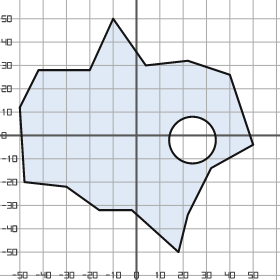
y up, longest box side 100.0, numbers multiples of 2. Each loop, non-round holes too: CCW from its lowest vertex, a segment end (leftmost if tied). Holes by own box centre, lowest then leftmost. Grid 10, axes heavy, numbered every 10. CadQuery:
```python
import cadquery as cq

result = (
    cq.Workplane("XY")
    .moveTo(18.0, -50.0)
    .lineTo(22.0, -34.0)
    .lineTo(32.0, -14.0)
    .lineTo(50.0, -4.0)
    .lineTo(40.0, 26.0)
    .lineTo(22.0, 32.0)
    .lineTo(4.0, 30.0)
    .lineTo(-10.0, 50.0)
    .lineTo(-20.0, 28.0)
    .lineTo(-42.0, 28.0)
    .lineTo(-50.0, 12.0)
    .lineTo(-48.0, -20.0)
    .lineTo(-30.0, -22.0)
    .lineTo(-16.0, -32.0)
    .lineTo(-2.0, -32.0)
    .close()
    .moveTo(24.0, -2.0)
    .circle(10.0)
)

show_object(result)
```